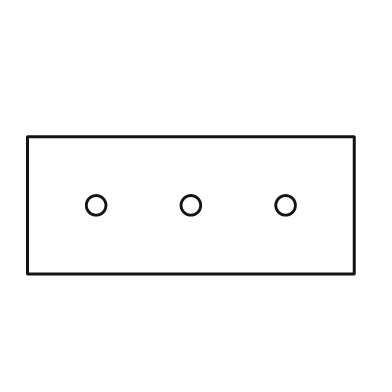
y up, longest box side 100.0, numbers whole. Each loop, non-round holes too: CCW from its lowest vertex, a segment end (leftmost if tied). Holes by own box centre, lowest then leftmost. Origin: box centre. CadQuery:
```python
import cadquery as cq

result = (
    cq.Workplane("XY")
    .moveTo(-50.0, -21.0)
    .lineTo(50.0, -21.0)
    .lineTo(50.0, 21.0)
    .lineTo(-50.0, 21.0)
    .close()
    .moveTo(-29.0, 0.0)
    .circle(3.0)
    .moveTo(0.0, 0.0)
    .circle(3.0)
    .moveTo(29.0, 0.0)
    .circle(3.0)
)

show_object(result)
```